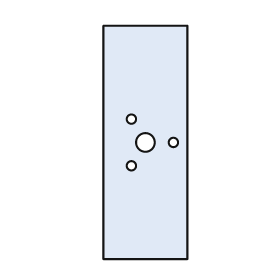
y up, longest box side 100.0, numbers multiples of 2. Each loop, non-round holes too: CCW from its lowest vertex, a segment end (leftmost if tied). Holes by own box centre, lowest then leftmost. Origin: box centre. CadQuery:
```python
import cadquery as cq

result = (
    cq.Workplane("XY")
    .moveTo(-18.0, -50.0)
    .lineTo(18.0, -50.0)
    .lineTo(18.0, 50.0)
    .lineTo(-18.0, 50.0)
    .close()
    .moveTo(-6.0, -10.0)
    .circle(2.0)
    .moveTo(0.0, 0.0)
    .circle(4.0)
    .moveTo(12.0, 0.0)
    .circle(2.0)
    .moveTo(-6.0, 10.0)
    .circle(2.0)
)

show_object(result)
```